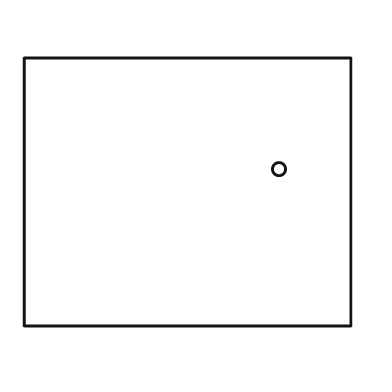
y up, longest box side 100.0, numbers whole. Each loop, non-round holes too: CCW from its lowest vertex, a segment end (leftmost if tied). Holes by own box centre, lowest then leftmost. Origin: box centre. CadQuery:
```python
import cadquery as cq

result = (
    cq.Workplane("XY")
    .moveTo(-50.0, -41.0)
    .lineTo(50.0, -41.0)
    .lineTo(50.0, 41.0)
    .lineTo(-50.0, 41.0)
    .close()
    .moveTo(28.0, 7.0)
    .circle(2.0)
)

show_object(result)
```